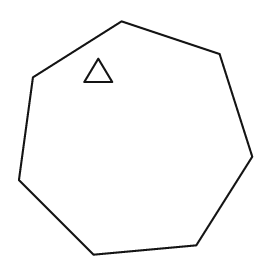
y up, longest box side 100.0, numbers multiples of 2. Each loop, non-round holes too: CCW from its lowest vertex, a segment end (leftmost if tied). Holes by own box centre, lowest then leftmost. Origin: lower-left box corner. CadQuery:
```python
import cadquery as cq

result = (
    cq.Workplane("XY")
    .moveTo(32.0, 0.0)
    .lineTo(76.0, 4.0)
    .lineTo(100.0, 42.0)
    .lineTo(86.0, 86.0)
    .lineTo(44.0, 100.0)
    .lineTo(6.0, 76.0)
    .lineTo(0.0, 32.0)
    .close()
    .moveTo(28.0, 74.0)
    .lineTo(40.0, 74.0)
    .lineTo(34.0, 84.0)
    .close()
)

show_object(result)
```